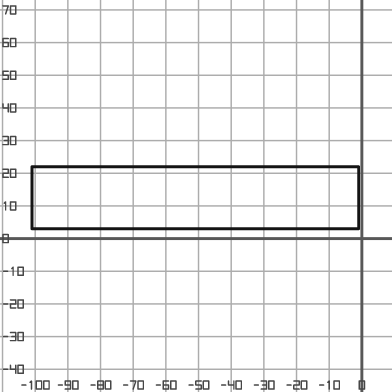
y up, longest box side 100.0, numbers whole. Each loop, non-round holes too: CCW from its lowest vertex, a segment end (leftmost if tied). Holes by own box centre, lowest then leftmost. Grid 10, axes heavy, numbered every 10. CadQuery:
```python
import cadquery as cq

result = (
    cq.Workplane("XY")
    .moveTo(-101.0, 3.0)
    .lineTo(-1.0, 3.0)
    .lineTo(-1.0, 22.0)
    .lineTo(-101.0, 22.0)
    .close()
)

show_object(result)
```